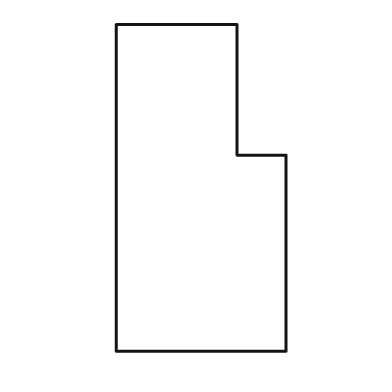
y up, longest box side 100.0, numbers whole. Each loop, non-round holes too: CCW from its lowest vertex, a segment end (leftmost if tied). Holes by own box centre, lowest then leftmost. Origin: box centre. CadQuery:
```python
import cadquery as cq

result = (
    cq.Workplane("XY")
    .moveTo(-26.0, -50.0)
    .lineTo(26.0, -50.0)
    .lineTo(26.0, 10.0)
    .lineTo(11.0, 10.0)
    .lineTo(11.0, 50.0)
    .lineTo(-26.0, 50.0)
    .close()
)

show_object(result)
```